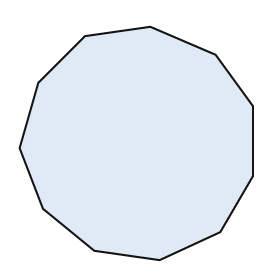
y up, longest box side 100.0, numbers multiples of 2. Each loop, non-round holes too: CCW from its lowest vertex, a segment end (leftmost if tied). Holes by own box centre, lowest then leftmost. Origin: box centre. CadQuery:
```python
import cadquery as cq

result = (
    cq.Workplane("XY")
    .moveTo(10.0, -50.0)
    .lineTo(36.0, -38.0)
    .lineTo(50.0, -14.0)
    .lineTo(50.0, 16.0)
    .lineTo(34.0, 38.0)
    .lineTo(6.0, 50.0)
    .lineTo(-22.0, 46.0)
    .lineTo(-42.0, 26.0)
    .lineTo(-50.0, -2.0)
    .lineTo(-40.0, -28.0)
    .lineTo(-18.0, -46.0)
    .close()
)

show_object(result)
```